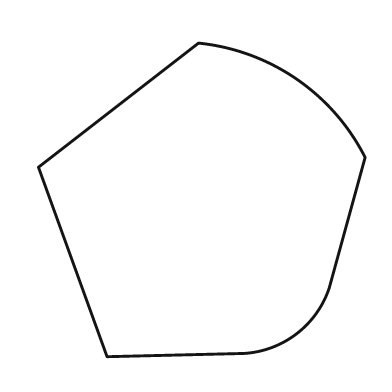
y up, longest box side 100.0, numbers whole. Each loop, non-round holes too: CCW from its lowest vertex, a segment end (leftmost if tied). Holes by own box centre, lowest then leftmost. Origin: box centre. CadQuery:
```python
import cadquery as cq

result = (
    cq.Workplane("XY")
    .moveTo(-29.0, -48.0)
    .lineTo(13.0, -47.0)
    .threePointArc((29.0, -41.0), (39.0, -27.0))
    .lineTo(50.0, 13.0)
    .threePointArc((29.0, 37.0), (-1.0, 48.0))
    .lineTo(-50.0, 10.0)
    .close()
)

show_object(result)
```